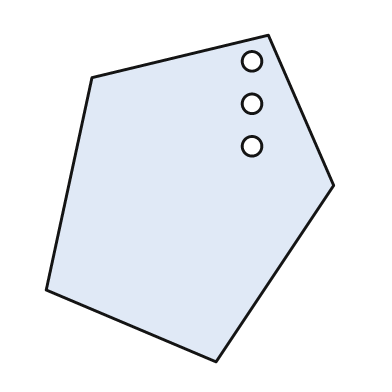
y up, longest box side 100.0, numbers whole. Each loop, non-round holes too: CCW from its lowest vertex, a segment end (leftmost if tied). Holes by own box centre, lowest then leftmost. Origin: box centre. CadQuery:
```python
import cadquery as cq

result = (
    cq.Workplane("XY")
    .moveTo(8.0, -50.0)
    .lineTo(44.0, 4.0)
    .lineTo(24.0, 50.0)
    .lineTo(-30.0, 37.0)
    .lineTo(-44.0, -28.0)
    .close()
    .moveTo(19.0, 16.0)
    .circle(3.0)
    .moveTo(19.0, 29.0)
    .circle(3.0)
    .moveTo(19.0, 42.0)
    .circle(3.0)
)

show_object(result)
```